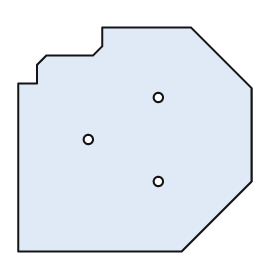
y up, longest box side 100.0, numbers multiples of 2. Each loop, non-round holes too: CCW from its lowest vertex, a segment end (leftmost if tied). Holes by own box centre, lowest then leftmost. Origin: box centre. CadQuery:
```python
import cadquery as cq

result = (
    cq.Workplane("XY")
    .moveTo(-50.0, -48.0)
    .lineTo(20.0, -48.0)
    .lineTo(50.0, -18.0)
    .lineTo(50.0, 22.0)
    .lineTo(24.0, 48.0)
    .lineTo(-14.0, 48.0)
    .lineTo(-14.0, 40.0)
    .lineTo(-18.0, 36.0)
    .lineTo(-38.0, 36.0)
    .lineTo(-42.0, 32.0)
    .lineTo(-42.0, 24.0)
    .lineTo(-50.0, 24.0)
    .close()
    .moveTo(10.0, -18.0)
    .circle(2.0)
    .moveTo(-20.0, 0.0)
    .circle(2.0)
    .moveTo(10.0, 18.0)
    .circle(2.0)
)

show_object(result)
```